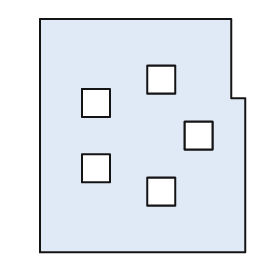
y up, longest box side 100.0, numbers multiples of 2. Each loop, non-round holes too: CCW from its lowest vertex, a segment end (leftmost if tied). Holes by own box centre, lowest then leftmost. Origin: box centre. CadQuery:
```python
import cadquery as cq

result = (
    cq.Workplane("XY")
    .moveTo(-44.0, -50.0)
    .lineTo(44.0, -50.0)
    .lineTo(44.0, 16.0)
    .lineTo(38.0, 16.0)
    .lineTo(38.0, 50.0)
    .lineTo(-44.0, 50.0)
    .close()
    .moveTo(2.0, -30.0)
    .lineTo(14.0, -30.0)
    .lineTo(14.0, -18.0)
    .lineTo(2.0, -18.0)
    .close()
    .moveTo(-26.0, -20.0)
    .lineTo(-14.0, -20.0)
    .lineTo(-14.0, -8.0)
    .lineTo(-26.0, -8.0)
    .close()
    .moveTo(18.0, -6.0)
    .lineTo(30.0, -6.0)
    .lineTo(30.0, 6.0)
    .lineTo(18.0, 6.0)
    .close()
    .moveTo(-26.0, 8.0)
    .lineTo(-14.0, 8.0)
    .lineTo(-14.0, 20.0)
    .lineTo(-26.0, 20.0)
    .close()
    .moveTo(2.0, 18.0)
    .lineTo(14.0, 18.0)
    .lineTo(14.0, 30.0)
    .lineTo(2.0, 30.0)
    .close()
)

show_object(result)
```